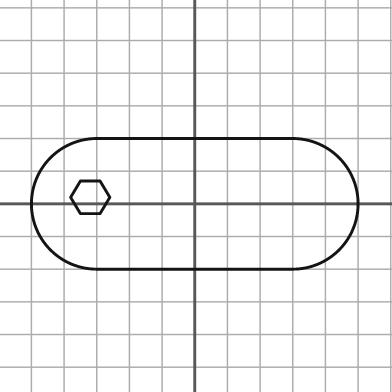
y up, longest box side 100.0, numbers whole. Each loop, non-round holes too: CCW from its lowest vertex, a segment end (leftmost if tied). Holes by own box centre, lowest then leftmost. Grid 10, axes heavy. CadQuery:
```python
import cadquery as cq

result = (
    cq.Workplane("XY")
    .moveTo(-30.0, -20.0)
    .lineTo(30.0, -20.0)
    .threePointArc((50.0, 0.0), (30.0, 20.0))
    .lineTo(-30.0, 20.0)
    .threePointArc((-50.0, 0.0), (-30.0, -20.0))
    .close()
    .moveTo(-35.0, -3.0)
    .lineTo(-29.0, -3.0)
    .lineTo(-26.0, 2.0)
    .lineTo(-29.0, 7.0)
    .lineTo(-35.0, 7.0)
    .lineTo(-38.0, 2.0)
    .close()
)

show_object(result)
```